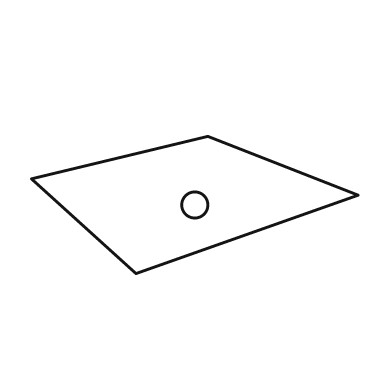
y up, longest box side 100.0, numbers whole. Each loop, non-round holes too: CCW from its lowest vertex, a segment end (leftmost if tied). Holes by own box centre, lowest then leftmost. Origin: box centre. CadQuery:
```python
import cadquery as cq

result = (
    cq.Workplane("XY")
    .moveTo(-18.0, -21.0)
    .lineTo(50.0, 3.0)
    .lineTo(4.0, 21.0)
    .lineTo(-50.0, 8.0)
    .close()
    .moveTo(0.0, 0.0)
    .circle(4.0)
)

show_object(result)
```